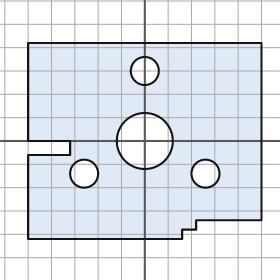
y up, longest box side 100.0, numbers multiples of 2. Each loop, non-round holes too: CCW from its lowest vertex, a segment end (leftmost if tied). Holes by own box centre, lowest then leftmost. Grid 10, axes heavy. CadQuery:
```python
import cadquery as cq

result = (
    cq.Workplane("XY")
    .moveTo(-50.0, -42.0)
    .lineTo(16.0, -42.0)
    .lineTo(16.0, -38.0)
    .lineTo(22.0, -38.0)
    .lineTo(22.0, -34.0)
    .lineTo(50.0, -34.0)
    .lineTo(50.0, 42.0)
    .lineTo(-50.0, 42.0)
    .lineTo(-50.0, 0.0)
    .lineTo(-32.0, 0.0)
    .lineTo(-32.0, -6.0)
    .lineTo(-50.0, -6.0)
    .close()
    .moveTo(-26.0, -14.0)
    .circle(6.0)
    .moveTo(26.0, -14.0)
    .circle(6.0)
    .moveTo(0.0, 0.0)
    .circle(12.0)
    .moveTo(0.0, 30.0)
    .circle(6.0)
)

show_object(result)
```